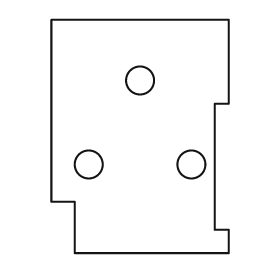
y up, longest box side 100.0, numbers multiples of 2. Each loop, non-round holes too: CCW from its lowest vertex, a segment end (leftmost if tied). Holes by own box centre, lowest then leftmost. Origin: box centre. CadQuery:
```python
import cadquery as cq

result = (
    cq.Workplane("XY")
    .moveTo(-28.0, -50.0)
    .lineTo(38.0, -50.0)
    .lineTo(38.0, -40.0)
    .lineTo(32.0, -40.0)
    .lineTo(32.0, 14.0)
    .lineTo(38.0, 14.0)
    .lineTo(38.0, 50.0)
    .lineTo(-38.0, 50.0)
    .lineTo(-38.0, -28.0)
    .lineTo(-28.0, -28.0)
    .close()
    .moveTo(-22.0, -12.0)
    .circle(6.0)
    .moveTo(22.0, -12.0)
    .circle(6.0)
    .moveTo(0.0, 24.0)
    .circle(6.0)
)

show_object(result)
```